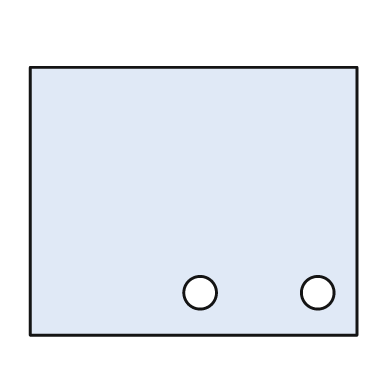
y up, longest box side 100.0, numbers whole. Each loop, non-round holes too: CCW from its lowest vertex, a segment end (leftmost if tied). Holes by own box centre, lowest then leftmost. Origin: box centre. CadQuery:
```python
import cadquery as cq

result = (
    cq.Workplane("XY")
    .moveTo(-50.0, -41.0)
    .lineTo(50.0, -41.0)
    .lineTo(50.0, 41.0)
    .lineTo(-50.0, 41.0)
    .close()
    .moveTo(2.0, -28.0)
    .circle(5.0)
    .moveTo(38.0, -28.0)
    .circle(5.0)
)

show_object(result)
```